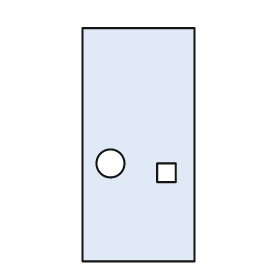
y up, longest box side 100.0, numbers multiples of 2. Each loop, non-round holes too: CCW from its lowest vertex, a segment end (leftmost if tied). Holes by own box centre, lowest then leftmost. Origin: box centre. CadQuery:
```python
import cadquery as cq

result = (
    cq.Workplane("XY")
    .moveTo(-24.0, -50.0)
    .lineTo(24.0, -50.0)
    .lineTo(24.0, 50.0)
    .lineTo(-24.0, 50.0)
    .close()
    .moveTo(8.0, -16.0)
    .lineTo(16.0, -16.0)
    .lineTo(16.0, -8.0)
    .lineTo(8.0, -8.0)
    .close()
    .moveTo(-12.0, -8.0)
    .circle(6.0)
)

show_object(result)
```